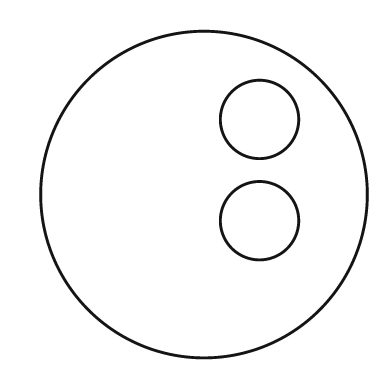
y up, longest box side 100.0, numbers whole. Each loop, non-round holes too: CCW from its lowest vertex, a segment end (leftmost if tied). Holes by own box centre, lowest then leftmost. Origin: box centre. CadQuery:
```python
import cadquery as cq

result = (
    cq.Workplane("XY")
    .moveTo(0.0, 0.0)
    .circle(50.0)
    .moveTo(17.0, -8.0)
    .circle(12.0)
    .moveTo(17.0, 23.0)
    .circle(12.0)
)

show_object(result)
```